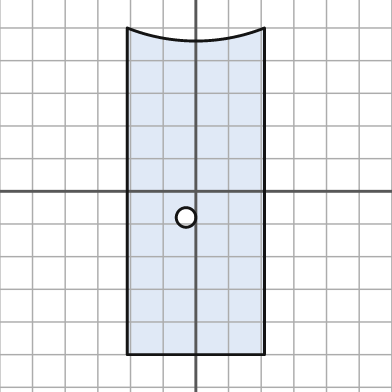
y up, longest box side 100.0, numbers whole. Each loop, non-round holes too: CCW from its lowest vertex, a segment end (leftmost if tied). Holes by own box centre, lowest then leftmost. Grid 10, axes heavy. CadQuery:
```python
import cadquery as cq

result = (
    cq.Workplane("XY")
    .moveTo(-21.0, -50.0)
    .lineTo(21.0, -50.0)
    .lineTo(21.0, 50.0)
    .threePointArc((0.0, 46.0), (-21.0, 50.0))
    .close()
    .moveTo(-3.0, -8.0)
    .circle(3.0)
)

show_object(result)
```